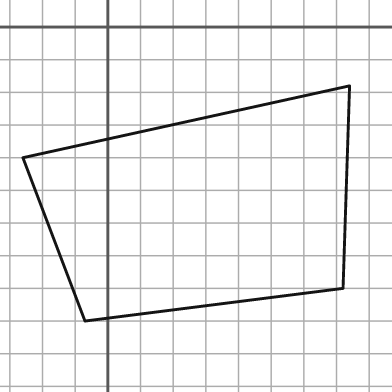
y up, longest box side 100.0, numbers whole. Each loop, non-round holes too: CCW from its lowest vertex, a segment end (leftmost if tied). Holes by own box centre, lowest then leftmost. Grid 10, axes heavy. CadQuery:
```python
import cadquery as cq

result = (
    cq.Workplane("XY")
    .moveTo(-7.0, -90.0)
    .lineTo(72.0, -80.0)
    .lineTo(74.0, -18.0)
    .lineTo(-26.0, -40.0)
    .close()
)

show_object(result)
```